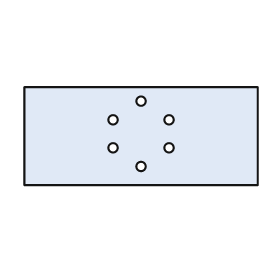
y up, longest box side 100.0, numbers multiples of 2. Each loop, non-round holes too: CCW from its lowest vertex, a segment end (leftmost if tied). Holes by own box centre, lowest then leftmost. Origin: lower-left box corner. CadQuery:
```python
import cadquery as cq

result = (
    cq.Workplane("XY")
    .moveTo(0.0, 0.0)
    .lineTo(100.0, 0.0)
    .lineTo(100.0, 42.0)
    .lineTo(0.0, 42.0)
    .close()
    .moveTo(50.0, 8.0)
    .circle(2.0)
    .moveTo(38.0, 16.0)
    .circle(2.0)
    .moveTo(62.0, 16.0)
    .circle(2.0)
    .moveTo(38.0, 28.0)
    .circle(2.0)
    .moveTo(62.0, 28.0)
    .circle(2.0)
    .moveTo(50.0, 36.0)
    .circle(2.0)
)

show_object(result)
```